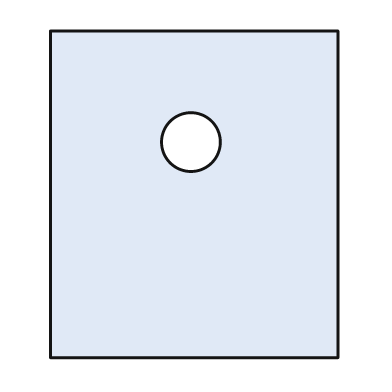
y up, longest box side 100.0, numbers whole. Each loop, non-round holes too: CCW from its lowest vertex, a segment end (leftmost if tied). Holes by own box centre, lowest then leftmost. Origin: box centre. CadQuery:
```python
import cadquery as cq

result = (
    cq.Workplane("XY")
    .moveTo(-44.0, -50.0)
    .lineTo(44.0, -50.0)
    .lineTo(44.0, 50.0)
    .lineTo(-44.0, 50.0)
    .close()
    .moveTo(-1.0, 16.0)
    .circle(9.0)
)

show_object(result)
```